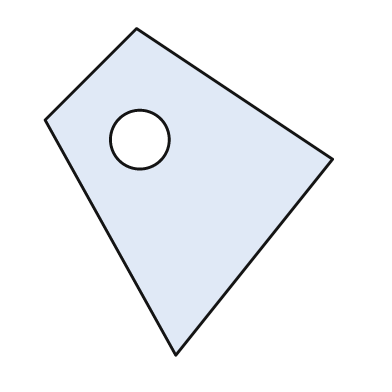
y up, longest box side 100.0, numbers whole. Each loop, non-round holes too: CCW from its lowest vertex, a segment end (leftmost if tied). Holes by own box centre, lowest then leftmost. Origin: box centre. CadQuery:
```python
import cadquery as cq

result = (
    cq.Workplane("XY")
    .moveTo(-4.0, -50.0)
    .lineTo(44.0, 10.0)
    .lineTo(-16.0, 50.0)
    .lineTo(-44.0, 22.0)
    .close()
    .moveTo(-15.0, 16.0)
    .circle(9.0)
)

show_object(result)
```